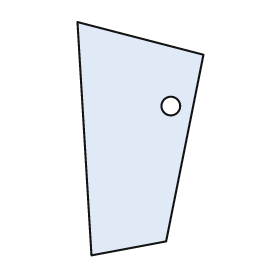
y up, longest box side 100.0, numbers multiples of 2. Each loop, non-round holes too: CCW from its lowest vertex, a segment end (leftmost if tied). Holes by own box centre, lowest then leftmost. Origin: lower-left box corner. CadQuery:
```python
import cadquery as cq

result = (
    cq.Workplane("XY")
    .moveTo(6.0, 0.0)
    .lineTo(38.0, 6.0)
    .lineTo(54.0, 86.0)
    .lineTo(0.0, 100.0)
    .close()
    .moveTo(40.0, 64.0)
    .circle(4.0)
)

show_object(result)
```